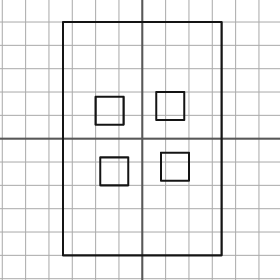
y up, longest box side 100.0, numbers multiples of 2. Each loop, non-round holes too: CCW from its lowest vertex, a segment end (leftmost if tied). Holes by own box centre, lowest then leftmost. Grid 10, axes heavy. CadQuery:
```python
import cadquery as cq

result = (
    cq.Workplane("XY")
    .moveTo(-34.0, -50.0)
    .lineTo(34.0, -50.0)
    .lineTo(34.0, 50.0)
    .lineTo(-34.0, 50.0)
    .close()
    .moveTo(-18.0, -20.0)
    .lineTo(-6.0, -20.0)
    .lineTo(-6.0, -8.0)
    .lineTo(-18.0, -8.0)
    .close()
    .moveTo(8.0, -18.0)
    .lineTo(20.0, -18.0)
    .lineTo(20.0, -6.0)
    .lineTo(8.0, -6.0)
    .close()
    .moveTo(-20.0, 6.0)
    .lineTo(-8.0, 6.0)
    .lineTo(-8.0, 18.0)
    .lineTo(-20.0, 18.0)
    .close()
    .moveTo(6.0, 8.0)
    .lineTo(18.0, 8.0)
    .lineTo(18.0, 20.0)
    .lineTo(6.0, 20.0)
    .close()
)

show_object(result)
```